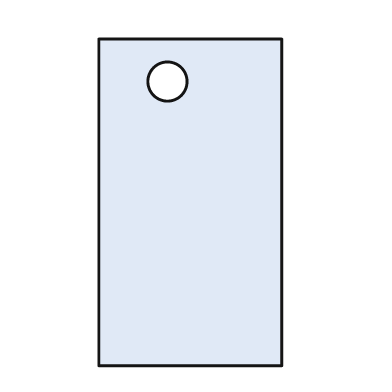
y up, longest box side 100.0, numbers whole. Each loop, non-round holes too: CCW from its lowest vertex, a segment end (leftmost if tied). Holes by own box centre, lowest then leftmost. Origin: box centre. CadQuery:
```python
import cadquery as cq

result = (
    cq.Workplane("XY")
    .moveTo(-28.0, -50.0)
    .lineTo(28.0, -50.0)
    .lineTo(28.0, 50.0)
    .lineTo(-28.0, 50.0)
    .close()
    .moveTo(-7.0, 37.0)
    .circle(6.0)
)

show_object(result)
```